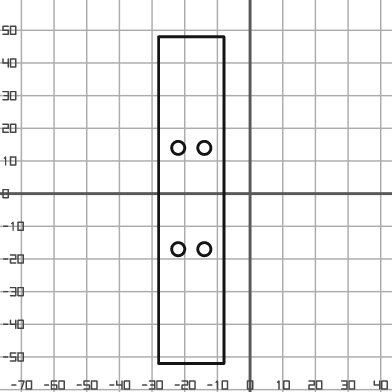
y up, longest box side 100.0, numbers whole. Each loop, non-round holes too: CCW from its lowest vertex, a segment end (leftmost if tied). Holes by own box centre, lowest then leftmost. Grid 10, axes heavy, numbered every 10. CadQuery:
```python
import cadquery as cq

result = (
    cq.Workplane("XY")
    .moveTo(-28.0, -52.0)
    .lineTo(-8.0, -52.0)
    .lineTo(-8.0, 48.0)
    .lineTo(-28.0, 48.0)
    .close()
    .moveTo(-22.0, -17.0)
    .circle(2.0)
    .moveTo(-14.0, -17.0)
    .circle(2.0)
    .moveTo(-22.0, 14.0)
    .circle(2.0)
    .moveTo(-14.0, 14.0)
    .circle(2.0)
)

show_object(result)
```